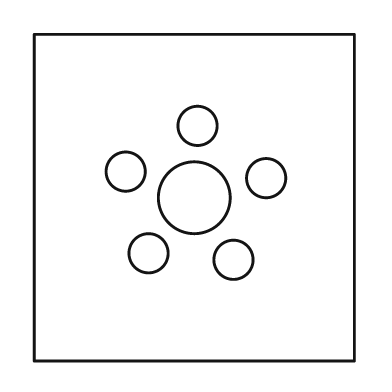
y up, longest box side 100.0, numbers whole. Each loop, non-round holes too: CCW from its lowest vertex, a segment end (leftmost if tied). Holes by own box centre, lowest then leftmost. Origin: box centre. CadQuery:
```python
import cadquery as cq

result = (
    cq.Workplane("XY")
    .moveTo(-49.0, -50.0)
    .lineTo(49.0, -50.0)
    .lineTo(49.0, 50.0)
    .lineTo(-49.0, 50.0)
    .close()
    .moveTo(12.0, -19.0)
    .circle(6.0)
    .moveTo(-14.0, -17.0)
    .circle(6.0)
    .moveTo(0.0, 0.0)
    .circle(11.0)
    .moveTo(22.0, 6.0)
    .circle(6.0)
    .moveTo(-21.0, 8.0)
    .circle(6.0)
    .moveTo(1.0, 22.0)
    .circle(6.0)
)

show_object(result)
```